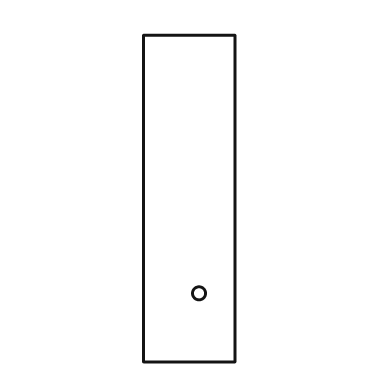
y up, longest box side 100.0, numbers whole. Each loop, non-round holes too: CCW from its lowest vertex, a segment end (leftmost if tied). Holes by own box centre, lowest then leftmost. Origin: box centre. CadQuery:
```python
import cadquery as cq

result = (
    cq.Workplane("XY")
    .moveTo(-14.0, -50.0)
    .lineTo(14.0, -50.0)
    .lineTo(14.0, 50.0)
    .lineTo(-14.0, 50.0)
    .close()
    .moveTo(3.0, -29.0)
    .circle(2.0)
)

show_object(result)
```